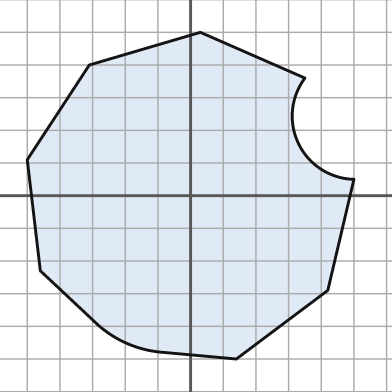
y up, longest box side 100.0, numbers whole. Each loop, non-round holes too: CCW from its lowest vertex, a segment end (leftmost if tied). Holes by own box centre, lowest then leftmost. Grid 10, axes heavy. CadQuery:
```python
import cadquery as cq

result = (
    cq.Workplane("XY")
    .moveTo(14.0, -50.0)
    .lineTo(42.0, -29.0)
    .lineTo(50.0, 5.0)
    .threePointArc((33.0, 16.0), (35.0, 36.0))
    .lineTo(3.0, 50.0)
    .lineTo(-31.0, 40.0)
    .lineTo(-50.0, 11.0)
    .lineTo(-46.0, -23.0)
    .lineTo(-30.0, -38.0)
    .threePointArc((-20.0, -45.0), (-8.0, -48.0))
    .close()
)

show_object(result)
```